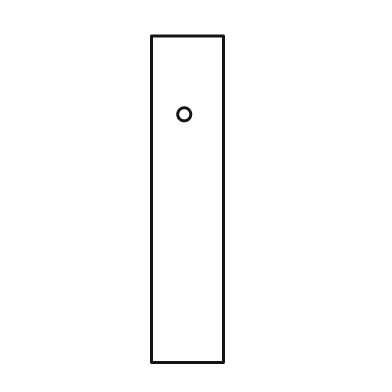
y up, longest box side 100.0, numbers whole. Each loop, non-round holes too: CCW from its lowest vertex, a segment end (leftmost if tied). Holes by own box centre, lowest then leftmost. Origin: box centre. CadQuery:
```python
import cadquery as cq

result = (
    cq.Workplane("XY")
    .moveTo(-11.0, -50.0)
    .lineTo(11.0, -50.0)
    .lineTo(11.0, 50.0)
    .lineTo(-11.0, 50.0)
    .close()
    .moveTo(-1.0, 26.0)
    .circle(2.0)
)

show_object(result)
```